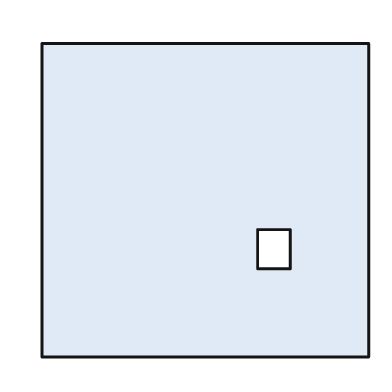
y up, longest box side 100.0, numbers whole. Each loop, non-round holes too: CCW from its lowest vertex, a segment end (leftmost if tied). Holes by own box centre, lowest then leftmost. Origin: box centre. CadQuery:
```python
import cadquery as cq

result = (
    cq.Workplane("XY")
    .moveTo(-50.0, -48.0)
    .lineTo(50.0, -48.0)
    .lineTo(50.0, 48.0)
    .lineTo(-50.0, 48.0)
    .close()
    .moveTo(16.0, -21.0)
    .lineTo(26.0, -21.0)
    .lineTo(26.0, -9.0)
    .lineTo(16.0, -9.0)
    .close()
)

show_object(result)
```